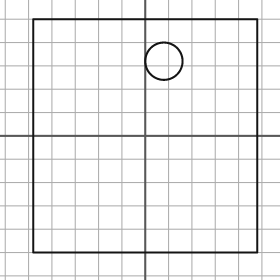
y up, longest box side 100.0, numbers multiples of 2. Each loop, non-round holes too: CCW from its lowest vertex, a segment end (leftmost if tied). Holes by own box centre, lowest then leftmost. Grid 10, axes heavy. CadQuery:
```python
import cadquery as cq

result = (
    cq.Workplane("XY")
    .moveTo(-48.0, -50.0)
    .lineTo(48.0, -50.0)
    .lineTo(48.0, 50.0)
    .lineTo(-48.0, 50.0)
    .close()
    .moveTo(8.0, 32.0)
    .circle(8.0)
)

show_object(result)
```